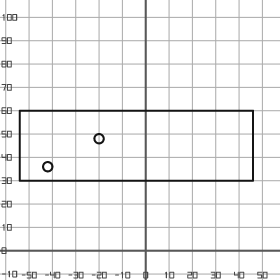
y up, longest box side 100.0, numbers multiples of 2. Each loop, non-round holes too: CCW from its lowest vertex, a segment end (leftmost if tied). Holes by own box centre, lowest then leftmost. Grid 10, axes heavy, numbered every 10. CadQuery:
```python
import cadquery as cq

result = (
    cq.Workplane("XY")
    .moveTo(-54.0, 30.0)
    .lineTo(46.0, 30.0)
    .lineTo(46.0, 60.0)
    .lineTo(-54.0, 60.0)
    .close()
    .moveTo(-42.0, 36.0)
    .circle(2.0)
    .moveTo(-20.0, 48.0)
    .circle(2.0)
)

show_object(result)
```